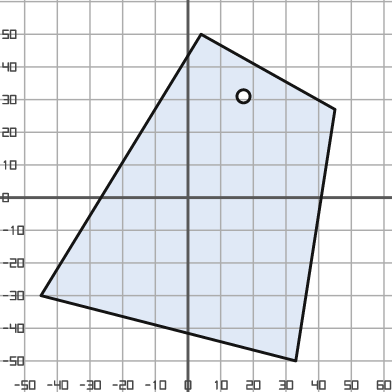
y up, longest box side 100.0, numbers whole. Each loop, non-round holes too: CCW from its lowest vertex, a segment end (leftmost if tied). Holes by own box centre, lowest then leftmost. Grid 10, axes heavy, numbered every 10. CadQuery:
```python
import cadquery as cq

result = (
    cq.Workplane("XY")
    .moveTo(33.0, -50.0)
    .lineTo(45.0, 27.0)
    .lineTo(4.0, 50.0)
    .lineTo(-45.0, -30.0)
    .close()
    .moveTo(17.0, 31.0)
    .circle(2.0)
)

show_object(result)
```